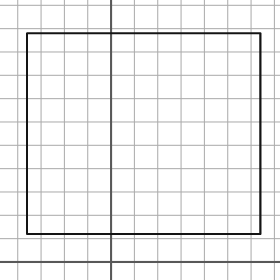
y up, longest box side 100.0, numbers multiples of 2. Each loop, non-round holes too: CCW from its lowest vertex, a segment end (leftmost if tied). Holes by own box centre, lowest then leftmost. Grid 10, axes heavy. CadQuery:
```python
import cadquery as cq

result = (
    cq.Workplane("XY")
    .moveTo(-36.0, 12.0)
    .lineTo(64.0, 12.0)
    .lineTo(64.0, 98.0)
    .lineTo(-36.0, 98.0)
    .close()
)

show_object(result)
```